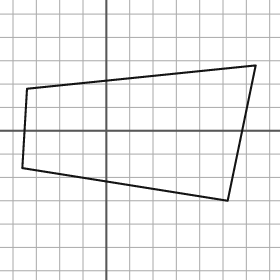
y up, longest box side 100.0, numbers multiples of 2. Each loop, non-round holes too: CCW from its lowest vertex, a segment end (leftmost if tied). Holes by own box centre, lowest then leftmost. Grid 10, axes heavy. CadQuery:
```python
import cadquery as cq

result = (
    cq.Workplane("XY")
    .moveTo(52.0, -30.0)
    .lineTo(64.0, 28.0)
    .lineTo(-34.0, 18.0)
    .lineTo(-36.0, -16.0)
    .close()
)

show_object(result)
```